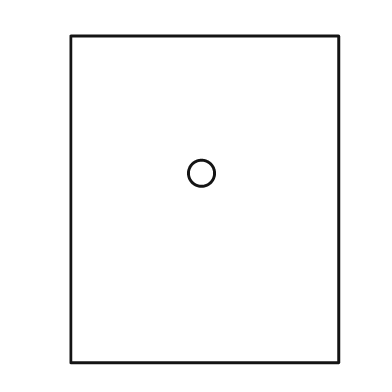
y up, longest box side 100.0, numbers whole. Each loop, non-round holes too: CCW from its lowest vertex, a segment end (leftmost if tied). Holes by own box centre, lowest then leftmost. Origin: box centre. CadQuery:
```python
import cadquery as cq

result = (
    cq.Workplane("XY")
    .moveTo(-41.0, -50.0)
    .lineTo(41.0, -50.0)
    .lineTo(41.0, 50.0)
    .lineTo(-41.0, 50.0)
    .close()
    .moveTo(-1.0, 8.0)
    .circle(4.0)
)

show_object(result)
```